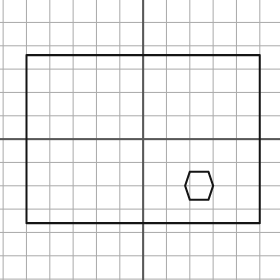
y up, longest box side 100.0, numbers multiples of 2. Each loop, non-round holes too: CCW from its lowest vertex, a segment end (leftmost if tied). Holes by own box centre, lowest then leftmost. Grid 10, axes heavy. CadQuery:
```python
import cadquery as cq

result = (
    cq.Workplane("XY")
    .moveTo(-50.0, -36.0)
    .lineTo(50.0, -36.0)
    .lineTo(50.0, 36.0)
    .lineTo(-50.0, 36.0)
    .close()
    .moveTo(20.0, -26.0)
    .lineTo(28.0, -26.0)
    .lineTo(30.0, -20.0)
    .lineTo(28.0, -14.0)
    .lineTo(20.0, -14.0)
    .lineTo(18.0, -20.0)
    .close()
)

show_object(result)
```